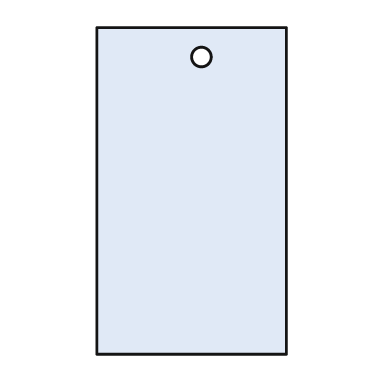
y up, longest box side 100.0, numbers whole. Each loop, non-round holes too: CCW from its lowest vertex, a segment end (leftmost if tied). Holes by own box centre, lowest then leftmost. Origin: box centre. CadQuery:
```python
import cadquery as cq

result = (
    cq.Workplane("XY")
    .moveTo(-29.0, -50.0)
    .lineTo(29.0, -50.0)
    .lineTo(29.0, 50.0)
    .lineTo(-29.0, 50.0)
    .close()
    .moveTo(3.0, 41.0)
    .circle(3.0)
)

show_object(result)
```